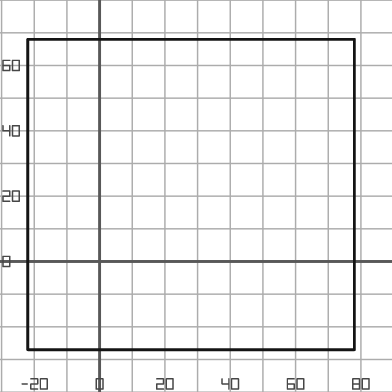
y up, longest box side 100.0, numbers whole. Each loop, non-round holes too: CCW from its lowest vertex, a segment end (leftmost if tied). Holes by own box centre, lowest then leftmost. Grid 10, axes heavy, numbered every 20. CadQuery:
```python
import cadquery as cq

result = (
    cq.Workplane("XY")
    .moveTo(-22.0, -27.0)
    .lineTo(78.0, -27.0)
    .lineTo(78.0, 68.0)
    .lineTo(-22.0, 68.0)
    .close()
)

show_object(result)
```